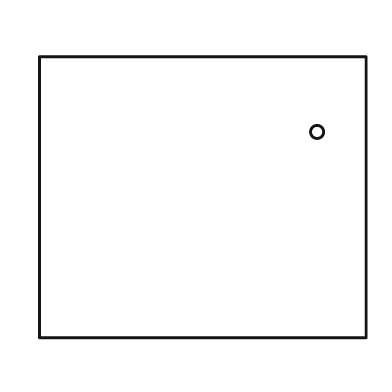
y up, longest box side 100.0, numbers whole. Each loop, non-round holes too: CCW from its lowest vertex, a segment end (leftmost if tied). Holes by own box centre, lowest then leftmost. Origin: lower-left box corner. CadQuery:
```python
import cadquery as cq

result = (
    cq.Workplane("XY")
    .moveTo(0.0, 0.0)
    .lineTo(100.0, 0.0)
    .lineTo(100.0, 86.0)
    .lineTo(0.0, 86.0)
    .close()
    .moveTo(85.0, 63.0)
    .circle(2.0)
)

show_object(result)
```